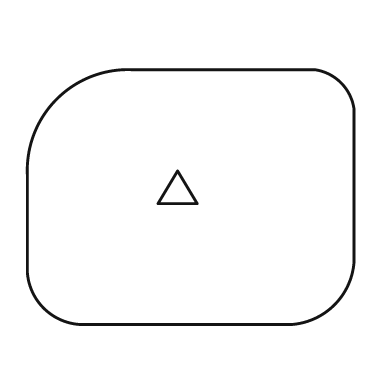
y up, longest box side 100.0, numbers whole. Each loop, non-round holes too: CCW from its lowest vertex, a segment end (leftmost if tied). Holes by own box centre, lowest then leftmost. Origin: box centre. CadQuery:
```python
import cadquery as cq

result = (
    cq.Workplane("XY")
    .moveTo(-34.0, -39.0)
    .lineTo(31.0, -39.0)
    .threePointArc((44.0, -33.0), (50.0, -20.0))
    .lineTo(50.0, 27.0)
    .threePointArc((46.0, 35.0), (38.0, 39.0))
    .lineTo(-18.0, 39.0)
    .threePointArc((-41.0, 30.0), (-50.0, 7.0))
    .lineTo(-50.0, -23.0)
    .threePointArc((-45.0, -34.0), (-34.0, -39.0))
    .close()
    .moveTo(-10.0, -2.0)
    .lineTo(2.0, -2.0)
    .lineTo(-4.0, 8.0)
    .close()
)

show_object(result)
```